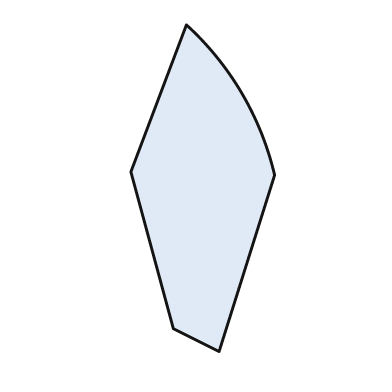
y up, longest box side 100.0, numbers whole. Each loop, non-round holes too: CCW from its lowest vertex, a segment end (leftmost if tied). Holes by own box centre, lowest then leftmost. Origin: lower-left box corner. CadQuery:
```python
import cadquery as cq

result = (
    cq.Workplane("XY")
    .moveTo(27.0, 0.0)
    .lineTo(44.0, 54.0)
    .threePointArc((34.0, 79.0), (17.0, 100.0))
    .lineTo(0.0, 55.0)
    .lineTo(13.0, 7.0)
    .close()
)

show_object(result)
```